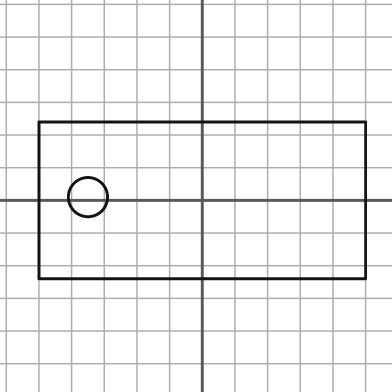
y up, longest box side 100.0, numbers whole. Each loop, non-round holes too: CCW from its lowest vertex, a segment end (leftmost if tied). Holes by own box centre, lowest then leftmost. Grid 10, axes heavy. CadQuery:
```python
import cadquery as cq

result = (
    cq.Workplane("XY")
    .moveTo(-50.0, -24.0)
    .lineTo(50.0, -24.0)
    .lineTo(50.0, 24.0)
    .lineTo(-50.0, 24.0)
    .close()
    .moveTo(-35.0, 1.0)
    .circle(6.0)
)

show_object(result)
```